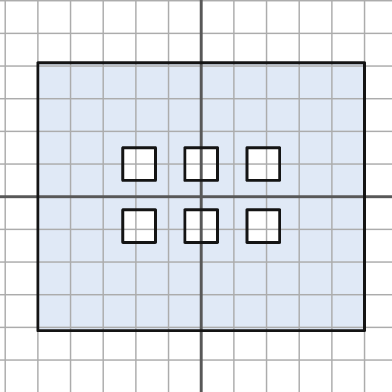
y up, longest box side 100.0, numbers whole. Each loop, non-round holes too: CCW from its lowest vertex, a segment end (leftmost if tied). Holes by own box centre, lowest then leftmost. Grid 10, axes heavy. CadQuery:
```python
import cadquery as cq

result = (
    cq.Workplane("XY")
    .moveTo(-50.0, -41.0)
    .lineTo(50.0, -41.0)
    .lineTo(50.0, 41.0)
    .lineTo(-50.0, 41.0)
    .close()
    .moveTo(-24.0, -14.0)
    .lineTo(-14.0, -14.0)
    .lineTo(-14.0, -4.0)
    .lineTo(-24.0, -4.0)
    .close()
    .moveTo(-5.0, -14.0)
    .lineTo(5.0, -14.0)
    .lineTo(5.0, -4.0)
    .lineTo(-5.0, -4.0)
    .close()
    .moveTo(14.0, -14.0)
    .lineTo(24.0, -14.0)
    .lineTo(24.0, -4.0)
    .lineTo(14.0, -4.0)
    .close()
    .moveTo(-24.0, 5.0)
    .lineTo(-14.0, 5.0)
    .lineTo(-14.0, 15.0)
    .lineTo(-24.0, 15.0)
    .close()
    .moveTo(-5.0, 5.0)
    .lineTo(5.0, 5.0)
    .lineTo(5.0, 15.0)
    .lineTo(-5.0, 15.0)
    .close()
    .moveTo(14.0, 5.0)
    .lineTo(24.0, 5.0)
    .lineTo(24.0, 15.0)
    .lineTo(14.0, 15.0)
    .close()
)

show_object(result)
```